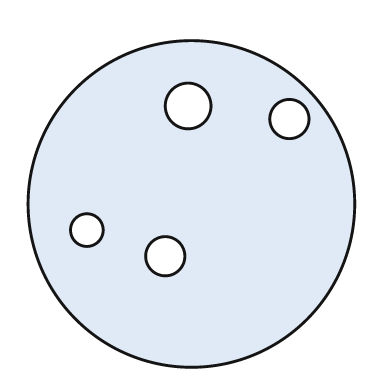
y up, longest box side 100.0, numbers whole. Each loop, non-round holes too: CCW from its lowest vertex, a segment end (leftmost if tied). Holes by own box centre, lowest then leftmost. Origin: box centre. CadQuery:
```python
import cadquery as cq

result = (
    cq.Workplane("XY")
    .moveTo(0.0, 0.0)
    .circle(50.0)
    .moveTo(-8.0, -16.0)
    .circle(6.0)
    .moveTo(-32.0, -8.0)
    .circle(5.0)
    .moveTo(30.0, 26.0)
    .circle(6.0)
    .moveTo(-1.0, 30.0)
    .circle(7.0)
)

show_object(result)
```